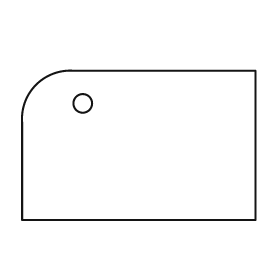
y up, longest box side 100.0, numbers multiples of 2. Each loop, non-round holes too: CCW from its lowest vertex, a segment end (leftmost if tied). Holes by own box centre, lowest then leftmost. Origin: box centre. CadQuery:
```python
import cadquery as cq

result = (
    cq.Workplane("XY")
    .moveTo(-50.0, -32.0)
    .lineTo(50.0, -32.0)
    .lineTo(50.0, 32.0)
    .lineTo(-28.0, 32.0)
    .threePointArc((-44.0, 26.0), (-50.0, 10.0))
    .close()
    .moveTo(-24.0, 18.0)
    .circle(4.0)
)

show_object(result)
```